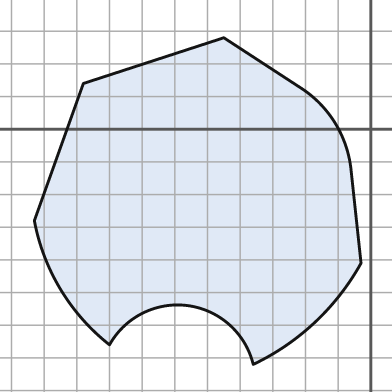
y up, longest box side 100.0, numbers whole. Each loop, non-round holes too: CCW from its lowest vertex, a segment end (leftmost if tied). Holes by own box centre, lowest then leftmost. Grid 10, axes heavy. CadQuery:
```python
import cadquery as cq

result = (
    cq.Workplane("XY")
    .moveTo(-36.0, -72.0)
    .threePointArc((-17.0, -59.0), (-3.0, -41.0))
    .lineTo(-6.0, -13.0)
    .threePointArc((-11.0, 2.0), (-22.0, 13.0))
    .lineTo(-45.0, 28.0)
    .lineTo(-88.0, 14.0)
    .lineTo(-103.0, -28.0)
    .threePointArc((-95.0, -49.0), (-80.0, -66.0))
    .threePointArc((-56.0, -54.0), (-36.0, -72.0))
    .close()
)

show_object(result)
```